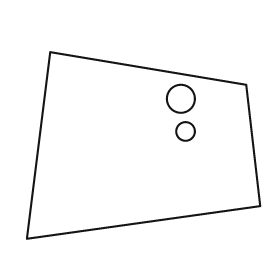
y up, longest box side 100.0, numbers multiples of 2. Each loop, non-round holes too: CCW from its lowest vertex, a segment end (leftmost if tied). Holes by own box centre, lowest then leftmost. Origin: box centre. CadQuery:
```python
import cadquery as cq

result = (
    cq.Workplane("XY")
    .moveTo(-50.0, -40.0)
    .lineTo(50.0, -26.0)
    .lineTo(44.0, 26.0)
    .lineTo(-40.0, 40.0)
    .close()
    .moveTo(18.0, 6.0)
    .circle(4.0)
    .moveTo(16.0, 20.0)
    .circle(6.0)
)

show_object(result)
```